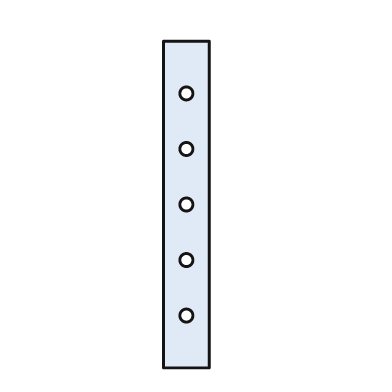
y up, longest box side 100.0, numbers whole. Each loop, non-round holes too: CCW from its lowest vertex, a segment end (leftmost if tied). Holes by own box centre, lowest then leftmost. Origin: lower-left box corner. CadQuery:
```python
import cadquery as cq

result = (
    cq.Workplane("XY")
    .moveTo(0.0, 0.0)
    .lineTo(14.0, 0.0)
    .lineTo(14.0, 100.0)
    .lineTo(0.0, 100.0)
    .close()
    .moveTo(7.0, 16.0)
    .circle(2.0)
    .moveTo(7.0, 33.0)
    .circle(2.0)
    .moveTo(7.0, 50.0)
    .circle(2.0)
    .moveTo(7.0, 67.0)
    .circle(2.0)
    .moveTo(7.0, 84.0)
    .circle(2.0)
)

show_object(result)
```